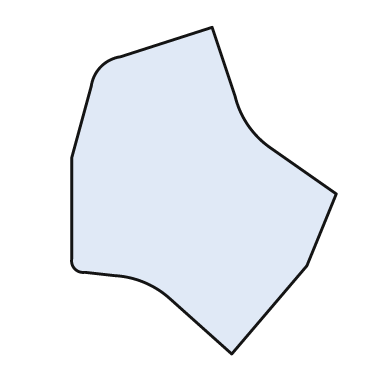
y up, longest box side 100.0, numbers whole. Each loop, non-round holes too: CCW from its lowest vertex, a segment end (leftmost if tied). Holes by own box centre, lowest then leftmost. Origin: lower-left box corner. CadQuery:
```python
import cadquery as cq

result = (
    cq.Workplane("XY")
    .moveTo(49.0, 0.0)
    .lineTo(72.0, 27.0)
    .lineTo(81.0, 49.0)
    .lineTo(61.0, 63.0)
    .threePointArc((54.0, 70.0), (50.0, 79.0))
    .lineTo(43.0, 100.0)
    .lineTo(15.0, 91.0)
    .threePointArc((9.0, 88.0), (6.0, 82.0))
    .lineTo(0.0, 60.0)
    .lineTo(0.0, 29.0)
    .threePointArc((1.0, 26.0), (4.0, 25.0))
    .lineTo(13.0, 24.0)
    .threePointArc((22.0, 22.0), (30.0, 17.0))
    .close()
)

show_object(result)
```